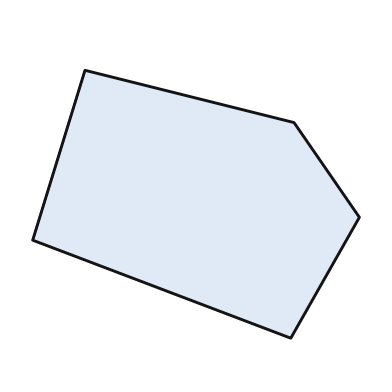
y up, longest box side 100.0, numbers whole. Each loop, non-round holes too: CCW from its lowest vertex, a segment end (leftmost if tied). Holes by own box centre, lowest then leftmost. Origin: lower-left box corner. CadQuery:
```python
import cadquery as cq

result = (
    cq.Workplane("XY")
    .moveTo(79.0, 0.0)
    .lineTo(100.0, 37.0)
    .lineTo(80.0, 66.0)
    .lineTo(16.0, 82.0)
    .lineTo(0.0, 30.0)
    .close()
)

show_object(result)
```